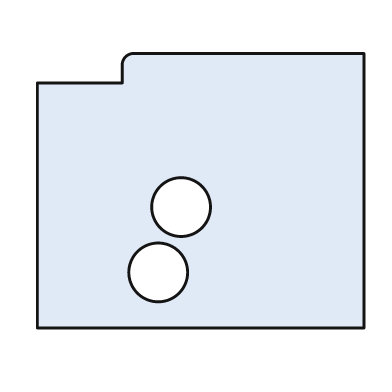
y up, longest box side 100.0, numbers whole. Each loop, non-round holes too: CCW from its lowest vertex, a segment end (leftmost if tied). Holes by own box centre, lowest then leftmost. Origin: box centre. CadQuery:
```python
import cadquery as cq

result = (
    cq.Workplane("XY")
    .moveTo(-50.0, -42.0)
    .lineTo(50.0, -42.0)
    .lineTo(50.0, 42.0)
    .lineTo(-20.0, 42.0)
    .threePointArc((-23.0, 41.0), (-24.0, 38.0))
    .lineTo(-24.0, 33.0)
    .lineTo(-50.0, 33.0)
    .close()
    .moveTo(-13.0, -25.0)
    .circle(9.0)
    .moveTo(-6.0, -5.0)
    .circle(9.0)
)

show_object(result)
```